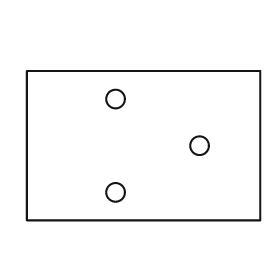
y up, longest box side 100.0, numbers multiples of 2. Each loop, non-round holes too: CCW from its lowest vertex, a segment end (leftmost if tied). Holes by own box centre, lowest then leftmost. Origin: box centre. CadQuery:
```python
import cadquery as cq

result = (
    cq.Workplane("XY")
    .moveTo(-50.0, -32.0)
    .lineTo(50.0, -32.0)
    .lineTo(50.0, 32.0)
    .lineTo(-50.0, 32.0)
    .close()
    .moveTo(-12.0, -20.0)
    .circle(4.0)
    .moveTo(24.0, 0.0)
    .circle(4.0)
    .moveTo(-12.0, 20.0)
    .circle(4.0)
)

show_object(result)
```